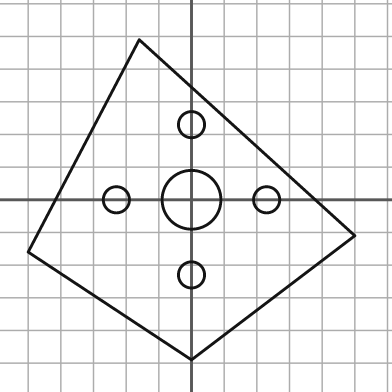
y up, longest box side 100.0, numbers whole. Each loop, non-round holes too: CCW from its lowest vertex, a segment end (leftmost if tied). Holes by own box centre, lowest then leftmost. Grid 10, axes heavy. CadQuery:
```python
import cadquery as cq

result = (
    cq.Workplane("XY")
    .moveTo(0.0, -49.0)
    .lineTo(50.0, -11.0)
    .lineTo(-16.0, 49.0)
    .lineTo(-50.0, -16.0)
    .close()
    .moveTo(0.0, -23.0)
    .circle(4.0)
    .moveTo(-23.0, 0.0)
    .circle(4.0)
    .moveTo(0.0, 0.0)
    .circle(9.0)
    .moveTo(23.0, 0.0)
    .circle(4.0)
    .moveTo(0.0, 23.0)
    .circle(4.0)
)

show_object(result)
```